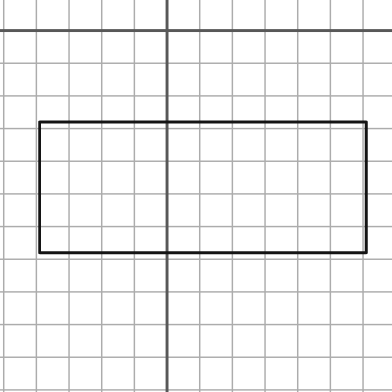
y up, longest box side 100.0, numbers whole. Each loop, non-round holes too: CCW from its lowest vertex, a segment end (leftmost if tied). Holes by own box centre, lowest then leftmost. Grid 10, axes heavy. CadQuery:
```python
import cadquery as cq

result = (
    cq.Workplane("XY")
    .moveTo(-39.0, -68.0)
    .lineTo(61.0, -68.0)
    .lineTo(61.0, -28.0)
    .lineTo(-39.0, -28.0)
    .close()
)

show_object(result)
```